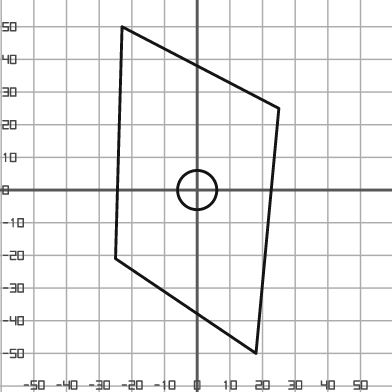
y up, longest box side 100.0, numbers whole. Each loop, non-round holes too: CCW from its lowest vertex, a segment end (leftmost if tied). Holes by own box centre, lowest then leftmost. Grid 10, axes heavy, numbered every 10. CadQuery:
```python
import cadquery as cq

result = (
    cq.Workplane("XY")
    .moveTo(18.0, -50.0)
    .lineTo(25.0, 25.0)
    .lineTo(-23.0, 50.0)
    .lineTo(-25.0, -21.0)
    .close()
    .moveTo(0.0, 0.0)
    .circle(6.0)
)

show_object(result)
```